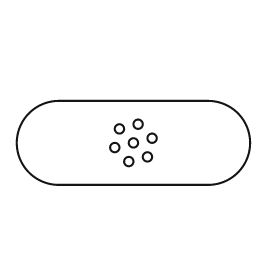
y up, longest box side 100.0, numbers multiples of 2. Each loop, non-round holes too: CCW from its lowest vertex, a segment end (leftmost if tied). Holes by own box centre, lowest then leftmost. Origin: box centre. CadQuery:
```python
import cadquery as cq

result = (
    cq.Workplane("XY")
    .moveTo(-32.0, -18.0)
    .lineTo(32.0, -18.0)
    .threePointArc((50.0, 0.0), (32.0, 18.0))
    .lineTo(-32.0, 18.0)
    .threePointArc((-50.0, 0.0), (-32.0, -18.0))
    .close()
    .moveTo(-2.0, -8.0)
    .circle(2.0)
    .moveTo(6.0, -6.0)
    .circle(2.0)
    .moveTo(-8.0, -2.0)
    .circle(2.0)
    .moveTo(0.0, 0.0)
    .circle(2.0)
    .moveTo(8.0, 2.0)
    .circle(2.0)
    .moveTo(-6.0, 6.0)
    .circle(2.0)
    .moveTo(2.0, 8.0)
    .circle(2.0)
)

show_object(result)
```